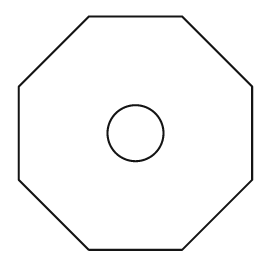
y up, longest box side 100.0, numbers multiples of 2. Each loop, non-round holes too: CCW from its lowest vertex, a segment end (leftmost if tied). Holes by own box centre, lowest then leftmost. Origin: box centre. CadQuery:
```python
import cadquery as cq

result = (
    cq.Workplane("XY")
    .moveTo(-20.0, -50.0)
    .lineTo(20.0, -50.0)
    .lineTo(50.0, -20.0)
    .lineTo(50.0, 20.0)
    .lineTo(20.0, 50.0)
    .lineTo(-20.0, 50.0)
    .lineTo(-50.0, 20.0)
    .lineTo(-50.0, -20.0)
    .close()
    .moveTo(0.0, 0.0)
    .circle(12.0)
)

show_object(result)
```